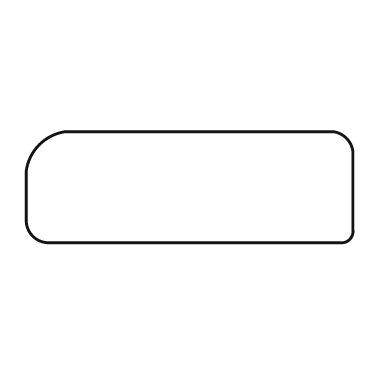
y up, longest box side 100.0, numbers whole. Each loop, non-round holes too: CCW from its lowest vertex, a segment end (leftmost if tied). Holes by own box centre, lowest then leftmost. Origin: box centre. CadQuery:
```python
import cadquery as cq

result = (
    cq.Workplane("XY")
    .moveTo(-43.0, -17.0)
    .lineTo(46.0, -17.0)
    .threePointArc((49.0, -16.0), (50.0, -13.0))
    .lineTo(50.0, 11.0)
    .threePointArc((48.0, 15.0), (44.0, 17.0))
    .lineTo(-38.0, 17.0)
    .threePointArc((-46.0, 13.0), (-50.0, 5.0))
    .lineTo(-50.0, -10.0)
    .threePointArc((-48.0, -15.0), (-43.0, -17.0))
    .close()
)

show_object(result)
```